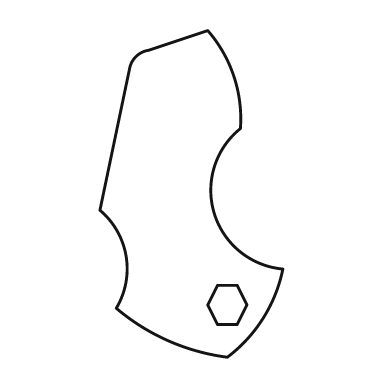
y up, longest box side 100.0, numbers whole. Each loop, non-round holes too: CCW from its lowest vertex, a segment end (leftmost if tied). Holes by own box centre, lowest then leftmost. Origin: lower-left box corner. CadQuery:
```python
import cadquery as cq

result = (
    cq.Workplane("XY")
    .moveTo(39.0, 0.0)
    .threePointArc((50.0, 12.0), (56.0, 27.0))
    .threePointArc((35.0, 44.0), (43.0, 70.0))
    .threePointArc((41.0, 86.0), (33.0, 100.0))
    .lineTo(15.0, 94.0)
    .threePointArc((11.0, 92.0), (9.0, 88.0))
    .lineTo(0.0, 45.0)
    .threePointArc((8.0, 31.0), (5.0, 15.0))
    .threePointArc((21.0, 5.0), (39.0, 0.0))
    .close()
    .moveTo(36.0, 10.0)
    .lineTo(42.0, 10.0)
    .lineTo(45.0, 16.0)
    .lineTo(42.0, 22.0)
    .lineTo(36.0, 22.0)
    .lineTo(33.0, 16.0)
    .close()
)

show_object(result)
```